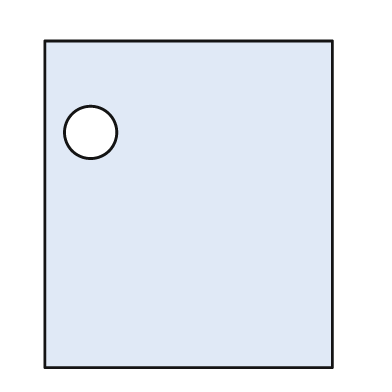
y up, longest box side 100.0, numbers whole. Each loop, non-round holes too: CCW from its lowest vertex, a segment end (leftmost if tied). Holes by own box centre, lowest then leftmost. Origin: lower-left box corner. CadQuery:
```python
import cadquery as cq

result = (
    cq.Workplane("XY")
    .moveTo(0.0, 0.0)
    .lineTo(88.0, 0.0)
    .lineTo(88.0, 100.0)
    .lineTo(0.0, 100.0)
    .close()
    .moveTo(14.0, 72.0)
    .circle(8.0)
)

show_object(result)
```